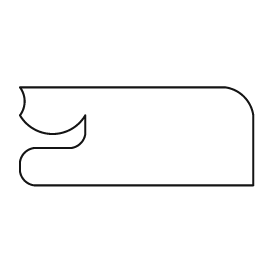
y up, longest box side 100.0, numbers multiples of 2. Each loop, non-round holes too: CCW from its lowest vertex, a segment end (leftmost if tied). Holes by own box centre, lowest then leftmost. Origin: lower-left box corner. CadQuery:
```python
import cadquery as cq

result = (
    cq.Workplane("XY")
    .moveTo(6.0, 0.0)
    .lineTo(100.0, 0.0)
    .lineTo(100.0, 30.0)
    .threePointArc((96.0, 38.0), (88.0, 42.0))
    .lineTo(0.0, 42.0)
    .threePointArc((2.0, 36.0), (0.0, 30.0))
    .threePointArc((14.0, 22.0), (28.0, 30.0))
    .lineTo(28.0, 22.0)
    .threePointArc((26.0, 18.0), (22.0, 16.0))
    .lineTo(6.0, 16.0)
    .threePointArc((2.0, 14.0), (0.0, 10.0))
    .lineTo(0.0, 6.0)
    .threePointArc((2.0, 2.0), (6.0, 0.0))
    .close()
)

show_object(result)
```